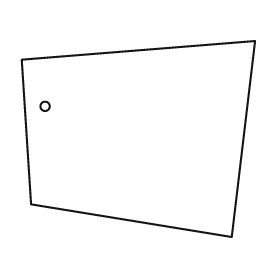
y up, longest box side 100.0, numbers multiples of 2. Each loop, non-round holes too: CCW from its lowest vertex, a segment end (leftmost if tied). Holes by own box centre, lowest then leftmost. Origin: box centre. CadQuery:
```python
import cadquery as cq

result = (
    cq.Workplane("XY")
    .moveTo(40.0, -42.0)
    .lineTo(50.0, 42.0)
    .lineTo(-50.0, 34.0)
    .lineTo(-46.0, -28.0)
    .close()
    .moveTo(-40.0, 14.0)
    .circle(2.0)
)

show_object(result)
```